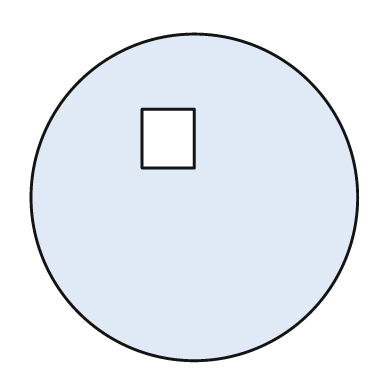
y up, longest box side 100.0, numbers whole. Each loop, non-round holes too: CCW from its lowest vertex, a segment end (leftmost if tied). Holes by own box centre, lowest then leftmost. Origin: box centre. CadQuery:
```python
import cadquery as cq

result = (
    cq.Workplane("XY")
    .moveTo(0.0, 0.0)
    .circle(50.0)
    .moveTo(-16.0, 9.0)
    .lineTo(0.0, 9.0)
    .lineTo(0.0, 27.0)
    .lineTo(-16.0, 27.0)
    .close()
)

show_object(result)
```